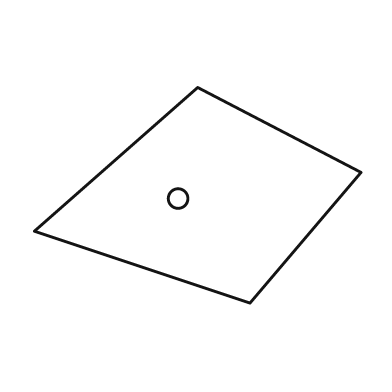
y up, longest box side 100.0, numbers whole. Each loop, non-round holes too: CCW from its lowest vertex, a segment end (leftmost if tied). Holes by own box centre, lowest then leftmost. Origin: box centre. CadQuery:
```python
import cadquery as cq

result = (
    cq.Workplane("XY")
    .moveTo(16.0, -33.0)
    .lineTo(50.0, 7.0)
    .lineTo(0.0, 33.0)
    .lineTo(-50.0, -11.0)
    .close()
    .moveTo(-6.0, -1.0)
    .circle(3.0)
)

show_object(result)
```